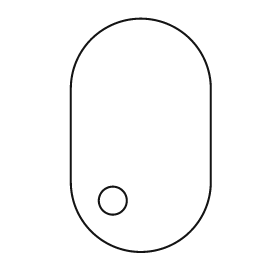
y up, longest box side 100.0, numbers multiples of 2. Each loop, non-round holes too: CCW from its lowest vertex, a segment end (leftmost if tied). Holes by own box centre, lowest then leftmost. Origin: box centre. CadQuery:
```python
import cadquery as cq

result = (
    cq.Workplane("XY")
    .moveTo(-30.0, -20.0)
    .threePointArc((0.0, -50.0), (30.0, -20.0))
    .lineTo(30.0, 20.0)
    .threePointArc((0.0, 50.0), (-30.0, 20.0))
    .close()
    .moveTo(-12.0, -28.0)
    .circle(6.0)
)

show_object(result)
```